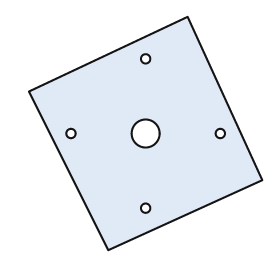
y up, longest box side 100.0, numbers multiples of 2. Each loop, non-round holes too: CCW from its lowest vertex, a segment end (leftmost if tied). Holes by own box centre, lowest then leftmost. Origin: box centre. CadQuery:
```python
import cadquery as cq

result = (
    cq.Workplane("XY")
    .moveTo(-16.0, -50.0)
    .lineTo(50.0, -20.0)
    .lineTo(18.0, 50.0)
    .lineTo(-50.0, 18.0)
    .close()
    .moveTo(0.0, -32.0)
    .circle(2.0)
    .moveTo(-32.0, 0.0)
    .circle(2.0)
    .moveTo(0.0, 0.0)
    .circle(6.0)
    .moveTo(32.0, 0.0)
    .circle(2.0)
    .moveTo(0.0, 32.0)
    .circle(2.0)
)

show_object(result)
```